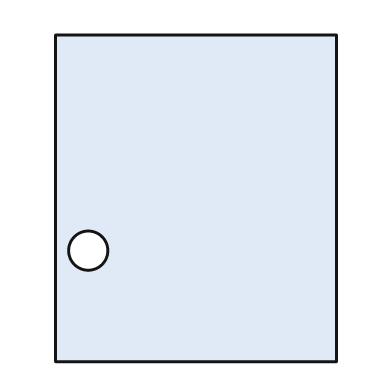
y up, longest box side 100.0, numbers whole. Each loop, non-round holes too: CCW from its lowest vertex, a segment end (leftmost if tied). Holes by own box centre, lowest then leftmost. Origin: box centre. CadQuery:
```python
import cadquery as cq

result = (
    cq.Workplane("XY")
    .moveTo(-43.0, -50.0)
    .lineTo(43.0, -50.0)
    .lineTo(43.0, 50.0)
    .lineTo(-43.0, 50.0)
    .close()
    .moveTo(-33.0, -16.0)
    .circle(6.0)
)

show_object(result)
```